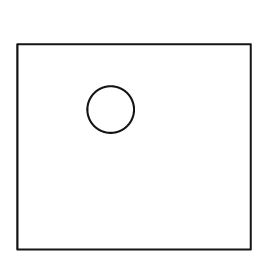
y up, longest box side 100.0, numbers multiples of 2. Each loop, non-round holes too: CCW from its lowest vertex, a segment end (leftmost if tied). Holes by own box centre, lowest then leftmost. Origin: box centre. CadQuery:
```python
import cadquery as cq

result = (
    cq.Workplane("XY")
    .moveTo(-50.0, -44.0)
    .lineTo(50.0, -44.0)
    .lineTo(50.0, 44.0)
    .lineTo(-50.0, 44.0)
    .close()
    .moveTo(-10.0, 16.0)
    .circle(10.0)
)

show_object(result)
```